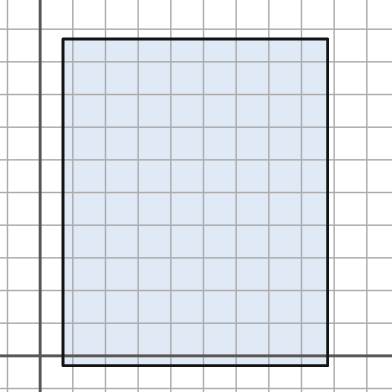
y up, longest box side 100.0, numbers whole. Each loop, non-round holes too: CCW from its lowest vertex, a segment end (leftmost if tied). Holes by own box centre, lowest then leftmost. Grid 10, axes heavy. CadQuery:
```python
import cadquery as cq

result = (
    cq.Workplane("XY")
    .moveTo(7.0, -3.0)
    .lineTo(88.0, -3.0)
    .lineTo(88.0, 97.0)
    .lineTo(7.0, 97.0)
    .close()
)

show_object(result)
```